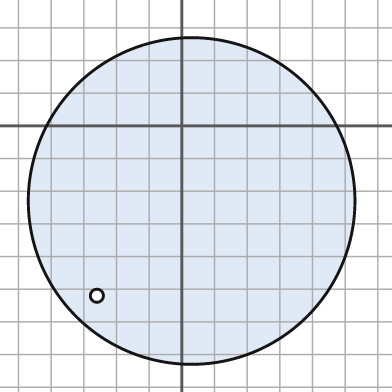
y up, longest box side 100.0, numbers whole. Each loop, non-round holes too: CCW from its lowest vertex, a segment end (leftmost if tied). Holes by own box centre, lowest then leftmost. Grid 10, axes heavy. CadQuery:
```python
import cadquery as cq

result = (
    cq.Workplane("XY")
    .moveTo(3.0, -23.0)
    .circle(50.0)
    .moveTo(-26.0, -52.0)
    .circle(2.0)
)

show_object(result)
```